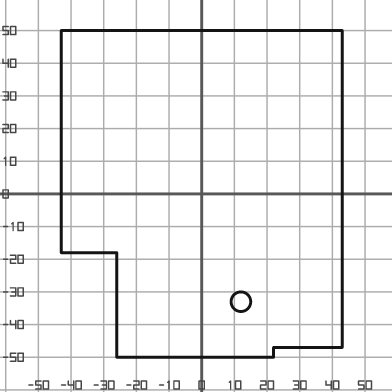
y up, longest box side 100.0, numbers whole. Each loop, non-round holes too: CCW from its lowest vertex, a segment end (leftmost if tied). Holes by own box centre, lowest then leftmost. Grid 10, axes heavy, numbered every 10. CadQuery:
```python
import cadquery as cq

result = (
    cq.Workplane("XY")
    .moveTo(-26.0, -50.0)
    .lineTo(22.0, -50.0)
    .lineTo(22.0, -47.0)
    .lineTo(43.0, -47.0)
    .lineTo(43.0, 50.0)
    .lineTo(-43.0, 50.0)
    .lineTo(-43.0, -18.0)
    .lineTo(-26.0, -18.0)
    .close()
    .moveTo(12.0, -33.0)
    .circle(3.0)
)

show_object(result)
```